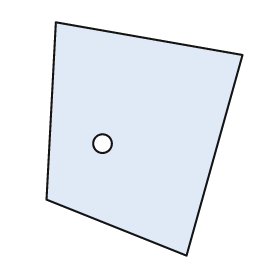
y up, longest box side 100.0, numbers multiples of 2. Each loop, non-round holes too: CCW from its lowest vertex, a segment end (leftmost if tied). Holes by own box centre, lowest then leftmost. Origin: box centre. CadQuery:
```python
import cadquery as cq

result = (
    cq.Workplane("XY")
    .moveTo(18.0, -50.0)
    .lineTo(42.0, 36.0)
    .lineTo(-38.0, 50.0)
    .lineTo(-42.0, -26.0)
    .close()
    .moveTo(-18.0, -2.0)
    .circle(4.0)
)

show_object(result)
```